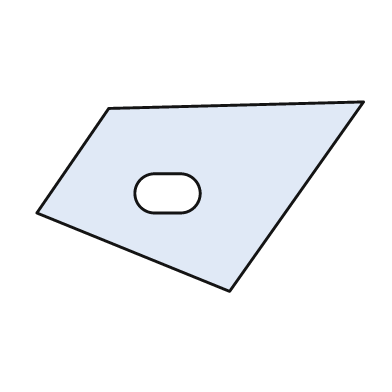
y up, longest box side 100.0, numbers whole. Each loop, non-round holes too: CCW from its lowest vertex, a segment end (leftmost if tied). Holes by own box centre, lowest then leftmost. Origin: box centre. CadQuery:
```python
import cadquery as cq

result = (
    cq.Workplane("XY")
    .moveTo(9.0, -29.0)
    .lineTo(50.0, 29.0)
    .lineTo(-28.0, 27.0)
    .lineTo(-50.0, -5.0)
    .close()
    .moveTo(-14.0, -5.0)
    .lineTo(-6.0, -5.0)
    .threePointArc((0.0, 1.0), (-6.0, 7.0))
    .lineTo(-14.0, 7.0)
    .threePointArc((-20.0, 1.0), (-14.0, -5.0))
    .close()
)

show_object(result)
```